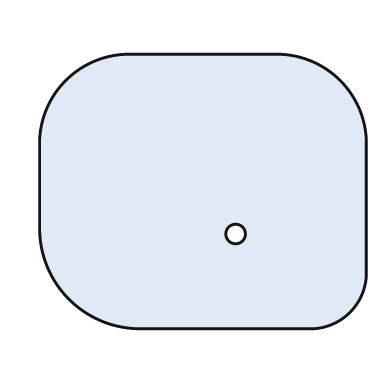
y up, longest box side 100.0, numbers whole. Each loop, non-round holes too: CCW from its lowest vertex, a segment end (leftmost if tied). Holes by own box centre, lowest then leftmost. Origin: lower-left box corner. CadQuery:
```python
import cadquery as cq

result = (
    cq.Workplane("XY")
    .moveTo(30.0, 0.0)
    .lineTo(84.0, 0.0)
    .threePointArc((95.0, 5.0), (100.0, 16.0))
    .lineTo(100.0, 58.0)
    .threePointArc((92.0, 76.0), (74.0, 84.0))
    .lineTo(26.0, 84.0)
    .threePointArc((8.0, 76.0), (0.0, 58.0))
    .lineTo(0.0, 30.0)
    .threePointArc((9.0, 9.0), (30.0, 0.0))
    .close()
    .moveTo(60.0, 29.0)
    .circle(3.0)
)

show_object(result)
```